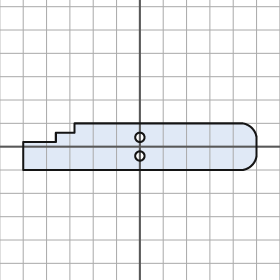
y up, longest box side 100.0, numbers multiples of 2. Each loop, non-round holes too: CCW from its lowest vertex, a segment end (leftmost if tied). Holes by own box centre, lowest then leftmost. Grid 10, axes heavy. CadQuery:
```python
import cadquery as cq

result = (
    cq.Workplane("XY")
    .moveTo(-50.0, -10.0)
    .lineTo(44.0, -10.0)
    .threePointArc((48.0, -8.0), (50.0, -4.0))
    .lineTo(50.0, 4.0)
    .threePointArc((48.0, 8.0), (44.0, 10.0))
    .lineTo(-28.0, 10.0)
    .lineTo(-28.0, 6.0)
    .lineTo(-36.0, 6.0)
    .lineTo(-36.0, 2.0)
    .lineTo(-50.0, 2.0)
    .close()
    .moveTo(0.0, -4.0)
    .circle(2.0)
    .moveTo(0.0, 4.0)
    .circle(2.0)
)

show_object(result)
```